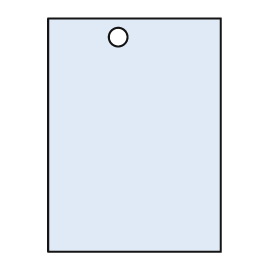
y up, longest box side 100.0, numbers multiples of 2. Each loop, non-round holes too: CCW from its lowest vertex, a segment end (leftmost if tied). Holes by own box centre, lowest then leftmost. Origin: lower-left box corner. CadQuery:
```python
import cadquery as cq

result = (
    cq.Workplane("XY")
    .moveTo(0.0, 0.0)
    .lineTo(74.0, 0.0)
    .lineTo(74.0, 100.0)
    .lineTo(0.0, 100.0)
    .close()
    .moveTo(30.0, 92.0)
    .circle(4.0)
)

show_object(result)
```